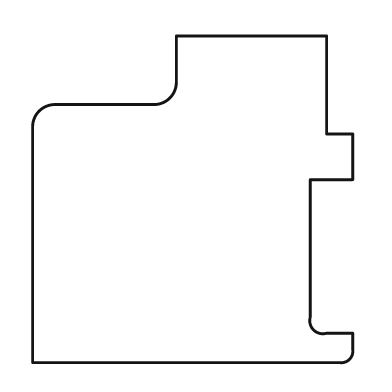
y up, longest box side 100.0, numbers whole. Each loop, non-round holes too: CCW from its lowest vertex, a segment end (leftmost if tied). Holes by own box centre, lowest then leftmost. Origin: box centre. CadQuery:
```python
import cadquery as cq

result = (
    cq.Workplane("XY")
    .moveTo(-49.0, -50.0)
    .lineTo(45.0, -50.0)
    .threePointArc((48.0, -49.0), (49.0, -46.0))
    .lineTo(49.0, -41.0)
    .lineTo(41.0, -41.0)
    .threePointArc((37.0, -40.0), (36.0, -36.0))
    .lineTo(36.0, 6.0)
    .lineTo(49.0, 6.0)
    .lineTo(49.0, 20.0)
    .lineTo(41.0, 20.0)
    .lineTo(41.0, 50.0)
    .lineTo(-5.0, 50.0)
    .lineTo(-5.0, 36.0)
    .threePointArc((-7.0, 31.0), (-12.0, 29.0))
    .lineTo(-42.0, 29.0)
    .threePointArc((-47.0, 27.0), (-49.0, 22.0))
    .close()
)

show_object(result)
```